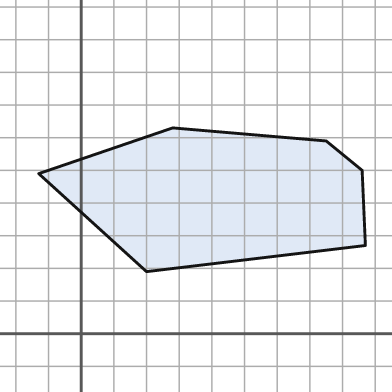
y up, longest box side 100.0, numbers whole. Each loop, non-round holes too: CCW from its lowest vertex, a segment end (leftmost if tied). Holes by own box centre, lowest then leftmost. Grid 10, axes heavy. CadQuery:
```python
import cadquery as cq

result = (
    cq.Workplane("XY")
    .moveTo(20.0, 19.0)
    .lineTo(87.0, 27.0)
    .lineTo(86.0, 50.0)
    .lineTo(75.0, 59.0)
    .lineTo(28.0, 63.0)
    .lineTo(-13.0, 49.0)
    .close()
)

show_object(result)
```